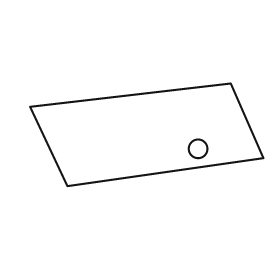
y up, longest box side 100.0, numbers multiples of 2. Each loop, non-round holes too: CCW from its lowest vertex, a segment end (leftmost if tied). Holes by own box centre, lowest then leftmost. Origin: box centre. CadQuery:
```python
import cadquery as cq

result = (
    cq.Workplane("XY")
    .moveTo(-34.0, -22.0)
    .lineTo(50.0, -10.0)
    .lineTo(36.0, 22.0)
    .lineTo(-50.0, 12.0)
    .close()
    .moveTo(22.0, -6.0)
    .circle(4.0)
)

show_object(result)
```